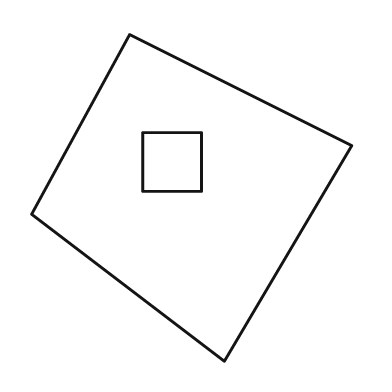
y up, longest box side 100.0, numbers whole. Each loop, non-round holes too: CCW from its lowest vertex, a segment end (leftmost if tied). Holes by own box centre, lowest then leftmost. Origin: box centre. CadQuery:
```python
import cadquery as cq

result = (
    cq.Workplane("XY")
    .moveTo(10.0, -50.0)
    .lineTo(49.0, 16.0)
    .lineTo(-19.0, 50.0)
    .lineTo(-49.0, -5.0)
    .close()
    .moveTo(-15.0, 2.0)
    .lineTo(3.0, 2.0)
    .lineTo(3.0, 20.0)
    .lineTo(-15.0, 20.0)
    .close()
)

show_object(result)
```